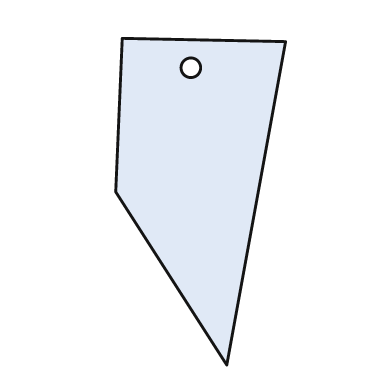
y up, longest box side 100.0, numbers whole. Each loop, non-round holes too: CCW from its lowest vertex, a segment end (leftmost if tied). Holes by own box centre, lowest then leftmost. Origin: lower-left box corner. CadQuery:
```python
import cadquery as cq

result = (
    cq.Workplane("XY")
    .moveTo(34.0, 0.0)
    .lineTo(52.0, 99.0)
    .lineTo(2.0, 100.0)
    .lineTo(0.0, 53.0)
    .close()
    .moveTo(23.0, 91.0)
    .circle(3.0)
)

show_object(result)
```